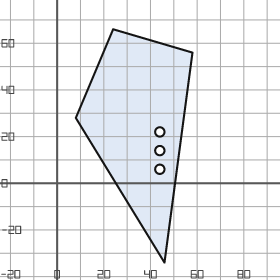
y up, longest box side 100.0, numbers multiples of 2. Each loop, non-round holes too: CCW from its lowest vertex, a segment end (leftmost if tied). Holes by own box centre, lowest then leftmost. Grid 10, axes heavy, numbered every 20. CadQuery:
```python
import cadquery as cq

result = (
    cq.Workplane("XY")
    .moveTo(46.0, -34.0)
    .lineTo(58.0, 56.0)
    .lineTo(24.0, 66.0)
    .lineTo(8.0, 28.0)
    .close()
    .moveTo(44.0, 6.0)
    .circle(2.0)
    .moveTo(44.0, 14.0)
    .circle(2.0)
    .moveTo(44.0, 22.0)
    .circle(2.0)
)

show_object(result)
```